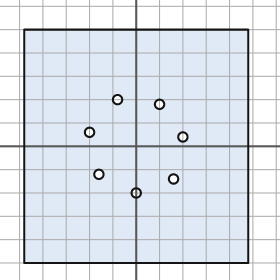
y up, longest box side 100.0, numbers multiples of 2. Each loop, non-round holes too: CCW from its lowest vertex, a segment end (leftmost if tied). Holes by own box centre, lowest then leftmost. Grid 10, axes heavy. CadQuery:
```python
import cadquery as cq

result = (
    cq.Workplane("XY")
    .moveTo(-48.0, -50.0)
    .lineTo(48.0, -50.0)
    .lineTo(48.0, 50.0)
    .lineTo(-48.0, 50.0)
    .close()
    .moveTo(0.0, -20.0)
    .circle(2.0)
    .moveTo(16.0, -14.0)
    .circle(2.0)
    .moveTo(-16.0, -12.0)
    .circle(2.0)
    .moveTo(20.0, 4.0)
    .circle(2.0)
    .moveTo(-20.0, 6.0)
    .circle(2.0)
    .moveTo(10.0, 18.0)
    .circle(2.0)
    .moveTo(-8.0, 20.0)
    .circle(2.0)
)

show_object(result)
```